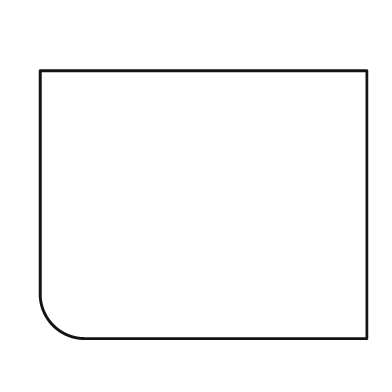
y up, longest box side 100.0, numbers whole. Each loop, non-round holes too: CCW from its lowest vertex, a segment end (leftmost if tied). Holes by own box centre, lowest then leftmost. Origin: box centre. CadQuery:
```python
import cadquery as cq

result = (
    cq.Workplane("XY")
    .moveTo(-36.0, -41.0)
    .lineTo(50.0, -41.0)
    .lineTo(50.0, 41.0)
    .lineTo(-50.0, 41.0)
    .lineTo(-50.0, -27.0)
    .threePointArc((-46.0, -37.0), (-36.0, -41.0))
    .close()
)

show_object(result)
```